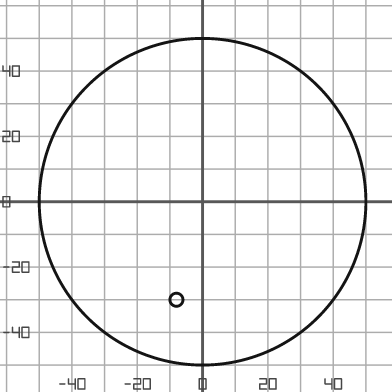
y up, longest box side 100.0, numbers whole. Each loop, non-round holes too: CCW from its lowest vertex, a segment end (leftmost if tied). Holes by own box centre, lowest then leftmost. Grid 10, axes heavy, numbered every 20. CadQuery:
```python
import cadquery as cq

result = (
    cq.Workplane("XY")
    .moveTo(0.0, 0.0)
    .circle(50.0)
    .moveTo(-8.0, -30.0)
    .circle(2.0)
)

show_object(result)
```